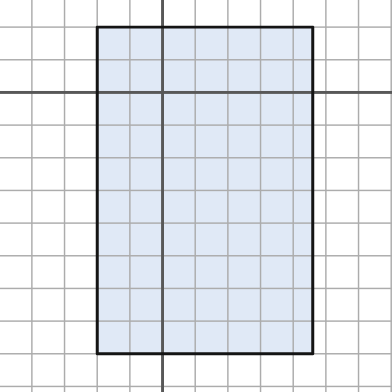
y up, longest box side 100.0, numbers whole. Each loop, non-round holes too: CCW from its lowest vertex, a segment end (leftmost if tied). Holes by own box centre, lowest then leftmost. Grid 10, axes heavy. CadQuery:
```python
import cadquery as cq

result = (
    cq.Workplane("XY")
    .moveTo(-20.0, -80.0)
    .lineTo(46.0, -80.0)
    .lineTo(46.0, 20.0)
    .lineTo(-20.0, 20.0)
    .close()
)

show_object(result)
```